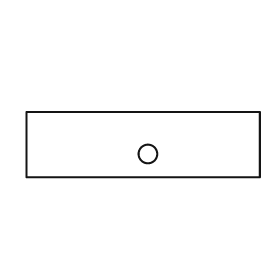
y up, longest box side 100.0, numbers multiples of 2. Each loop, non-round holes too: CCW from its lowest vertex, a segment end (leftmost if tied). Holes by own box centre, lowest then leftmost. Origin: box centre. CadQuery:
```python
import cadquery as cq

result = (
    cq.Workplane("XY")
    .moveTo(-50.0, -14.0)
    .lineTo(50.0, -14.0)
    .lineTo(50.0, 14.0)
    .lineTo(-50.0, 14.0)
    .close()
    .moveTo(2.0, -4.0)
    .circle(4.0)
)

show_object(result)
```